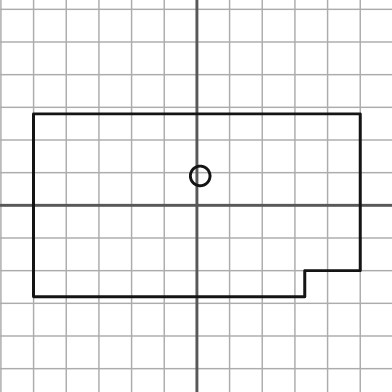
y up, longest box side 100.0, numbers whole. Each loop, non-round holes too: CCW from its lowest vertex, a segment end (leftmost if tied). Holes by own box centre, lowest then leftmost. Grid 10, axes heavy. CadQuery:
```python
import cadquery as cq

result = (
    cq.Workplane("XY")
    .moveTo(-50.0, -28.0)
    .lineTo(33.0, -28.0)
    .lineTo(33.0, -20.0)
    .lineTo(50.0, -20.0)
    .lineTo(50.0, 28.0)
    .lineTo(-50.0, 28.0)
    .close()
    .moveTo(1.0, 9.0)
    .circle(3.0)
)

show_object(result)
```